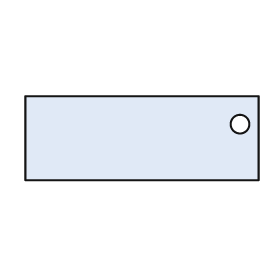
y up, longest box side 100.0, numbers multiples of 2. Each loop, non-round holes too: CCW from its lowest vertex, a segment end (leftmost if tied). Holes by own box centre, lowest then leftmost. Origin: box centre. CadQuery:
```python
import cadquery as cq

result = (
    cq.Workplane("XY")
    .moveTo(-50.0, -18.0)
    .lineTo(50.0, -18.0)
    .lineTo(50.0, 18.0)
    .lineTo(-50.0, 18.0)
    .close()
    .moveTo(42.0, 6.0)
    .circle(4.0)
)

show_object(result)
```